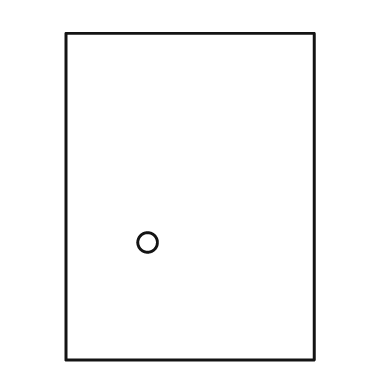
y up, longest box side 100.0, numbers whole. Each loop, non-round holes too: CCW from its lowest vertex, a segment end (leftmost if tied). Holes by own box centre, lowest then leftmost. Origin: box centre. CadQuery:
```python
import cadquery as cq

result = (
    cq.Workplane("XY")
    .moveTo(-38.0, -50.0)
    .lineTo(38.0, -50.0)
    .lineTo(38.0, 50.0)
    .lineTo(-38.0, 50.0)
    .close()
    .moveTo(-13.0, -14.0)
    .circle(3.0)
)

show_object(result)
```